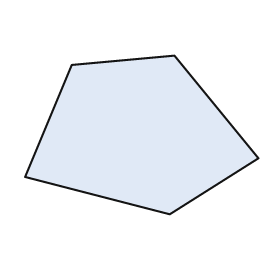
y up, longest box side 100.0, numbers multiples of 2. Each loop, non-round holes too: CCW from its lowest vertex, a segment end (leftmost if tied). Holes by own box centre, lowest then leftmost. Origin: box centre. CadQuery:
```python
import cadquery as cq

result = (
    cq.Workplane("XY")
    .moveTo(12.0, -34.0)
    .lineTo(50.0, -10.0)
    .lineTo(14.0, 34.0)
    .lineTo(-30.0, 30.0)
    .lineTo(-50.0, -18.0)
    .close()
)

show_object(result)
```